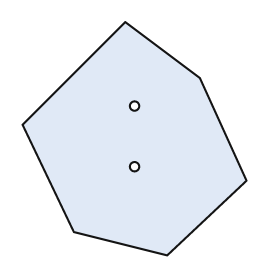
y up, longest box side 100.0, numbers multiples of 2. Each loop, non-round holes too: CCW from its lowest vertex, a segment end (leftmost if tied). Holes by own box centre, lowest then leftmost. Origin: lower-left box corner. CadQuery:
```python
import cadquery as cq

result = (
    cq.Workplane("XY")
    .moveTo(62.0, 0.0)
    .lineTo(96.0, 32.0)
    .lineTo(76.0, 76.0)
    .lineTo(44.0, 100.0)
    .lineTo(0.0, 56.0)
    .lineTo(22.0, 10.0)
    .close()
    .moveTo(48.0, 38.0)
    .circle(2.0)
    .moveTo(48.0, 64.0)
    .circle(2.0)
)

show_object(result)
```